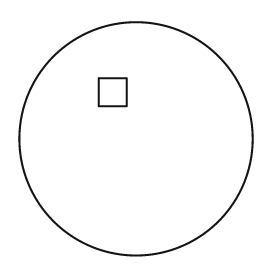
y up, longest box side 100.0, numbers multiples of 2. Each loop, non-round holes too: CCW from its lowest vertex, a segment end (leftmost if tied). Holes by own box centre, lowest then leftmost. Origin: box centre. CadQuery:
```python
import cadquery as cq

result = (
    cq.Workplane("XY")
    .moveTo(0.0, 0.0)
    .circle(50.0)
    .moveTo(-16.0, 14.0)
    .lineTo(-4.0, 14.0)
    .lineTo(-4.0, 26.0)
    .lineTo(-16.0, 26.0)
    .close()
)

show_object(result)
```